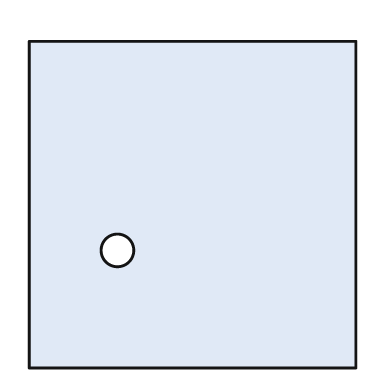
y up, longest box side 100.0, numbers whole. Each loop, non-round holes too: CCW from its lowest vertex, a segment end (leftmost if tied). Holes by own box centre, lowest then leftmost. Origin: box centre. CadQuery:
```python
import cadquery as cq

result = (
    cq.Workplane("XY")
    .moveTo(-50.0, -50.0)
    .lineTo(50.0, -50.0)
    .lineTo(50.0, 50.0)
    .lineTo(-50.0, 50.0)
    .close()
    .moveTo(-23.0, -14.0)
    .circle(5.0)
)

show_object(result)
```